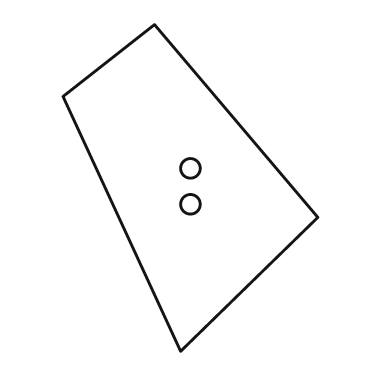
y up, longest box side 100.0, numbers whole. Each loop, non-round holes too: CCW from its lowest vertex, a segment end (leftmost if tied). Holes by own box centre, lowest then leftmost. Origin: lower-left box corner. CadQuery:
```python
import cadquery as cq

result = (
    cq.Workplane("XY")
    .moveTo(36.0, 0.0)
    .lineTo(78.0, 41.0)
    .lineTo(28.0, 100.0)
    .lineTo(0.0, 78.0)
    .close()
    .moveTo(39.0, 45.0)
    .circle(3.0)
    .moveTo(39.0, 56.0)
    .circle(3.0)
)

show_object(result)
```